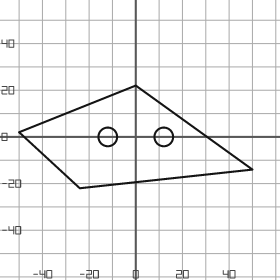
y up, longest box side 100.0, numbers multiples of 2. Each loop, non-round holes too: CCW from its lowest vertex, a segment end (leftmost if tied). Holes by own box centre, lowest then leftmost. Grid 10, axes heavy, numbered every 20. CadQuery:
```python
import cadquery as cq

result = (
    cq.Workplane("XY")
    .moveTo(-24.0, -22.0)
    .lineTo(50.0, -14.0)
    .lineTo(0.0, 22.0)
    .lineTo(-50.0, 2.0)
    .close()
    .moveTo(-12.0, 0.0)
    .circle(4.0)
    .moveTo(12.0, 0.0)
    .circle(4.0)
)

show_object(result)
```